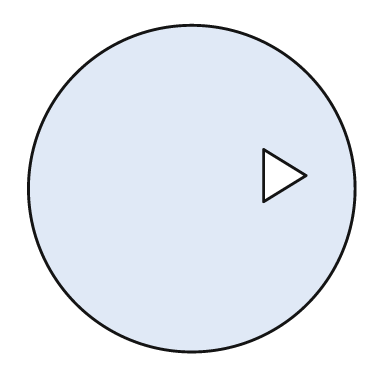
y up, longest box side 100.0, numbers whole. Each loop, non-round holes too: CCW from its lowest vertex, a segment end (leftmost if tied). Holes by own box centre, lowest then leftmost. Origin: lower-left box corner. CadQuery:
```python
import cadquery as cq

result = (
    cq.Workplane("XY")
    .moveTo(50.0, 50.0)
    .circle(50.0)
    .moveTo(72.0, 46.0)
    .lineTo(85.0, 54.0)
    .lineTo(72.0, 62.0)
    .close()
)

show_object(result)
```